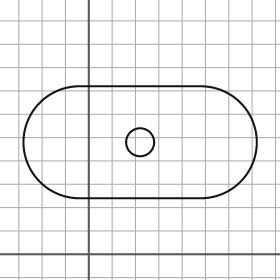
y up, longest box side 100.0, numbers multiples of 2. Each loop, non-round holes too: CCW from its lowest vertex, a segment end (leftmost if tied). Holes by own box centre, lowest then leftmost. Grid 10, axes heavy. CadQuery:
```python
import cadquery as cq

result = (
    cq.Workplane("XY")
    .moveTo(-4.0, 24.0)
    .lineTo(48.0, 24.0)
    .threePointArc((72.0, 48.0), (48.0, 72.0))
    .lineTo(-4.0, 72.0)
    .threePointArc((-28.0, 48.0), (-4.0, 24.0))
    .close()
    .moveTo(22.0, 48.0)
    .circle(6.0)
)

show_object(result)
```